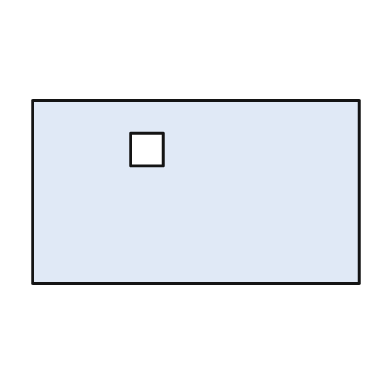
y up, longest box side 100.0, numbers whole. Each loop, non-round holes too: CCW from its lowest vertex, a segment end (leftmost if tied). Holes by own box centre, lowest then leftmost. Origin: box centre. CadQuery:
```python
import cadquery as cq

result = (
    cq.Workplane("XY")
    .moveTo(-50.0, -28.0)
    .lineTo(50.0, -28.0)
    .lineTo(50.0, 28.0)
    .lineTo(-50.0, 28.0)
    .close()
    .moveTo(-20.0, 8.0)
    .lineTo(-10.0, 8.0)
    .lineTo(-10.0, 18.0)
    .lineTo(-20.0, 18.0)
    .close()
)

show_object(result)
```